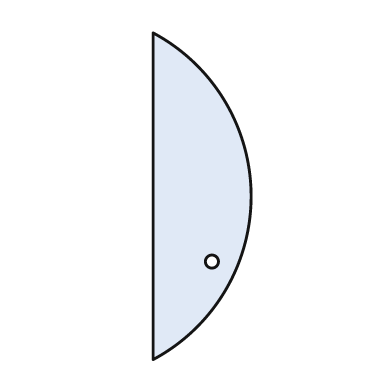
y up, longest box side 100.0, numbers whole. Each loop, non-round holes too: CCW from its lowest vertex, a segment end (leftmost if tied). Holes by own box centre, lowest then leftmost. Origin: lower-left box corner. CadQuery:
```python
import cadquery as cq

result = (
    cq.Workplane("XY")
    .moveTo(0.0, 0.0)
    .threePointArc((30.0, 50.0), (0.0, 100.0))
    .close()
    .moveTo(18.0, 30.0)
    .circle(2.0)
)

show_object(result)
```